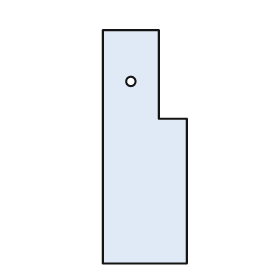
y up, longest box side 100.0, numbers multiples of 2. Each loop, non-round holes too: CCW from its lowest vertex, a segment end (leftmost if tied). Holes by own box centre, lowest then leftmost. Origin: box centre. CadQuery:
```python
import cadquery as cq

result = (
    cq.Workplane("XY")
    .moveTo(-18.0, -50.0)
    .lineTo(18.0, -50.0)
    .lineTo(18.0, 12.0)
    .lineTo(6.0, 12.0)
    .lineTo(6.0, 50.0)
    .lineTo(-18.0, 50.0)
    .close()
    .moveTo(-6.0, 28.0)
    .circle(2.0)
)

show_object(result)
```